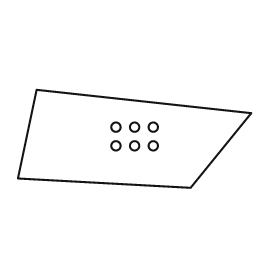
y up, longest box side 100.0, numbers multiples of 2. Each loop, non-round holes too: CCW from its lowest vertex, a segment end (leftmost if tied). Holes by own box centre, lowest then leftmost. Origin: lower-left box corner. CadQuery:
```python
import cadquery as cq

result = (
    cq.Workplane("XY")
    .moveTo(74.0, 0.0)
    .lineTo(100.0, 32.0)
    .lineTo(8.0, 42.0)
    .lineTo(0.0, 4.0)
    .close()
    .moveTo(42.0, 18.0)
    .circle(2.0)
    .moveTo(50.0, 18.0)
    .circle(2.0)
    .moveTo(58.0, 18.0)
    .circle(2.0)
    .moveTo(42.0, 26.0)
    .circle(2.0)
    .moveTo(50.0, 26.0)
    .circle(2.0)
    .moveTo(58.0, 26.0)
    .circle(2.0)
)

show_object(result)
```